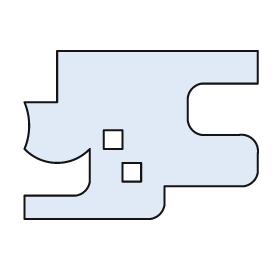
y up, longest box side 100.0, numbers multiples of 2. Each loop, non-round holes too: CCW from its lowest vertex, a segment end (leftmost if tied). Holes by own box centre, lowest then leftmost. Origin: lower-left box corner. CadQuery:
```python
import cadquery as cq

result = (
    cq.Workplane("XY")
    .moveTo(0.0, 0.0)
    .lineTo(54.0, 0.0)
    .threePointArc((58.0, 2.0), (60.0, 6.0))
    .lineTo(60.0, 14.0)
    .lineTo(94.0, 14.0)
    .threePointArc((98.0, 16.0), (100.0, 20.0))
    .lineTo(100.0, 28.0)
    .threePointArc((98.0, 34.0), (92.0, 36.0))
    .lineTo(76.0, 36.0)
    .threePointArc((72.0, 38.0), (70.0, 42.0))
    .lineTo(70.0, 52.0)
    .threePointArc((72.0, 56.0), (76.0, 58.0))
    .lineTo(100.0, 58.0)
    .lineTo(100.0, 72.0)
    .lineTo(14.0, 72.0)
    .lineTo(14.0, 50.0)
    .lineTo(0.0, 50.0)
    .threePointArc((2.0, 40.0), (0.0, 30.0))
    .threePointArc((14.0, 24.0), (28.0, 30.0))
    .lineTo(28.0, 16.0)
    .threePointArc((26.0, 12.0), (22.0, 10.0))
    .lineTo(0.0, 10.0)
    .close()
    .moveTo(42.0, 16.0)
    .lineTo(50.0, 16.0)
    .lineTo(50.0, 24.0)
    .lineTo(42.0, 24.0)
    .close()
    .moveTo(34.0, 30.0)
    .lineTo(42.0, 30.0)
    .lineTo(42.0, 38.0)
    .lineTo(34.0, 38.0)
    .close()
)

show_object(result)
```